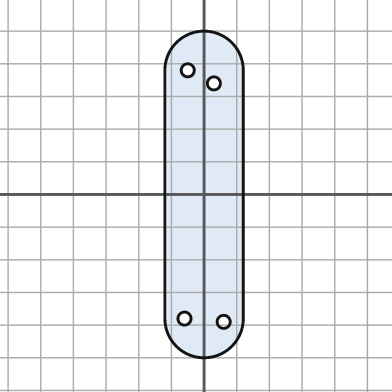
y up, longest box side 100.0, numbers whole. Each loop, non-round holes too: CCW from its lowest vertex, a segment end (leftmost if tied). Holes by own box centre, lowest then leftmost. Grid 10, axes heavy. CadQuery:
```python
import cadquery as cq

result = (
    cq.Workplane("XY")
    .moveTo(-12.0, -38.0)
    .threePointArc((0.0, -50.0), (12.0, -38.0))
    .lineTo(12.0, 38.0)
    .threePointArc((0.0, 50.0), (-12.0, 38.0))
    .close()
    .moveTo(6.0, -39.0)
    .circle(2.0)
    .moveTo(-6.0, -38.0)
    .circle(2.0)
    .moveTo(3.0, 34.0)
    .circle(2.0)
    .moveTo(-5.0, 38.0)
    .circle(2.0)
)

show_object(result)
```